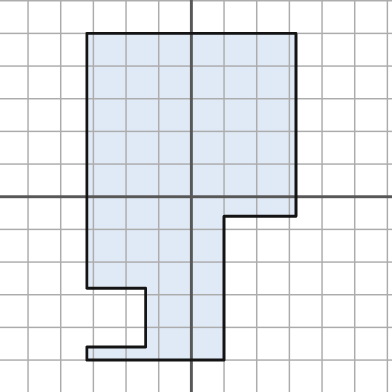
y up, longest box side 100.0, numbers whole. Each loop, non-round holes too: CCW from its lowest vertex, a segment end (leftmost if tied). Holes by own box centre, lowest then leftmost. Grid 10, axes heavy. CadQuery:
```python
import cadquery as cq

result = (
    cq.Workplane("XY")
    .moveTo(-32.0, -50.0)
    .lineTo(10.0, -50.0)
    .lineTo(10.0, -6.0)
    .lineTo(32.0, -6.0)
    .lineTo(32.0, 50.0)
    .lineTo(-32.0, 50.0)
    .lineTo(-32.0, -28.0)
    .lineTo(-14.0, -28.0)
    .lineTo(-14.0, -46.0)
    .lineTo(-32.0, -46.0)
    .close()
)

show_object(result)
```